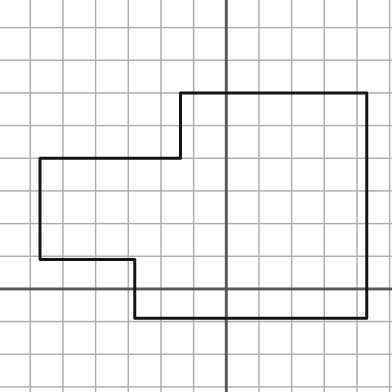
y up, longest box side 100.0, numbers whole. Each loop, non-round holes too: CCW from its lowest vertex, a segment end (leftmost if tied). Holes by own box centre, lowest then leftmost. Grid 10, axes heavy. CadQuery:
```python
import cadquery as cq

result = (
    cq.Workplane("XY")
    .moveTo(-28.0, -9.0)
    .lineTo(43.0, -9.0)
    .lineTo(43.0, 60.0)
    .lineTo(-14.0, 60.0)
    .lineTo(-14.0, 40.0)
    .lineTo(-57.0, 40.0)
    .lineTo(-57.0, 9.0)
    .lineTo(-28.0, 9.0)
    .close()
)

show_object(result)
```